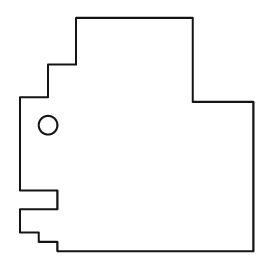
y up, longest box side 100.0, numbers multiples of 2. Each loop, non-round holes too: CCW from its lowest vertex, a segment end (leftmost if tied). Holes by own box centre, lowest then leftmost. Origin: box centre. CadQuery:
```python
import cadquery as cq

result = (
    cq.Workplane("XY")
    .moveTo(-34.0, -50.0)
    .lineTo(50.0, -50.0)
    .lineTo(50.0, 14.0)
    .lineTo(24.0, 14.0)
    .lineTo(24.0, 50.0)
    .lineTo(-26.0, 50.0)
    .lineTo(-26.0, 30.0)
    .lineTo(-38.0, 30.0)
    .lineTo(-38.0, 16.0)
    .lineTo(-50.0, 16.0)
    .lineTo(-50.0, -24.0)
    .lineTo(-34.0, -24.0)
    .lineTo(-34.0, -32.0)
    .lineTo(-50.0, -32.0)
    .lineTo(-50.0, -42.0)
    .lineTo(-42.0, -42.0)
    .lineTo(-42.0, -46.0)
    .lineTo(-34.0, -46.0)
    .close()
    .moveTo(-38.0, 4.0)
    .circle(4.0)
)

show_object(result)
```